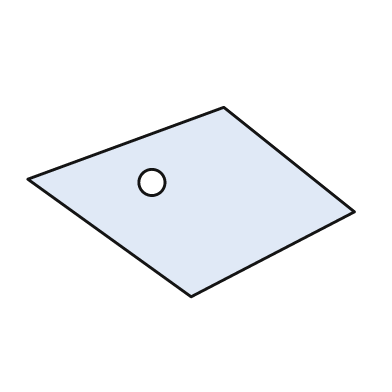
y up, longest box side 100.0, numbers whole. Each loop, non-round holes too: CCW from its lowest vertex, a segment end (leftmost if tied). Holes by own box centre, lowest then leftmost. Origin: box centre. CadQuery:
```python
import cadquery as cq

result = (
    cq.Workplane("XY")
    .moveTo(0.0, -29.0)
    .lineTo(50.0, -3.0)
    .lineTo(10.0, 29.0)
    .lineTo(-50.0, 7.0)
    .close()
    .moveTo(-12.0, 6.0)
    .circle(4.0)
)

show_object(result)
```